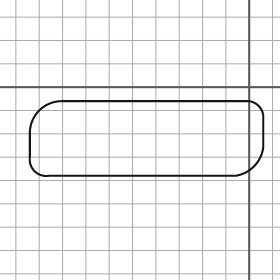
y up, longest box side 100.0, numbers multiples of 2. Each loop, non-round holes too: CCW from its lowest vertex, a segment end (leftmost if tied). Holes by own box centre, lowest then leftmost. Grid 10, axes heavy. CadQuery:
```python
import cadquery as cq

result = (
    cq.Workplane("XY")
    .moveTo(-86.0, -38.0)
    .lineTo(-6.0, -38.0)
    .threePointArc((2.0, -34.0), (6.0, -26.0))
    .lineTo(6.0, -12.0)
    .threePointArc((4.0, -8.0), (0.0, -6.0))
    .lineTo(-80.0, -6.0)
    .threePointArc((-90.0, -10.0), (-94.0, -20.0))
    .lineTo(-94.0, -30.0)
    .threePointArc((-92.0, -36.0), (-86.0, -38.0))
    .close()
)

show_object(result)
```